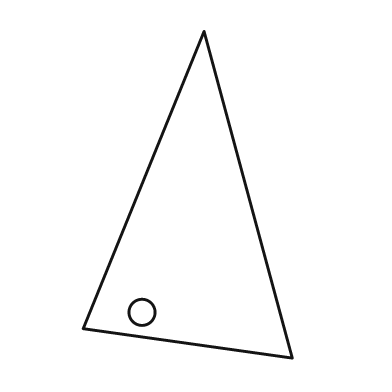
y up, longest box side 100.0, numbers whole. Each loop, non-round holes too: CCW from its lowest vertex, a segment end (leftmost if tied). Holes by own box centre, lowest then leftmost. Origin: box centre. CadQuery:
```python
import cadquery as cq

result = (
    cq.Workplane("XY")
    .moveTo(32.0, -50.0)
    .lineTo(5.0, 50.0)
    .lineTo(-32.0, -41.0)
    .close()
    .moveTo(-14.0, -36.0)
    .circle(4.0)
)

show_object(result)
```